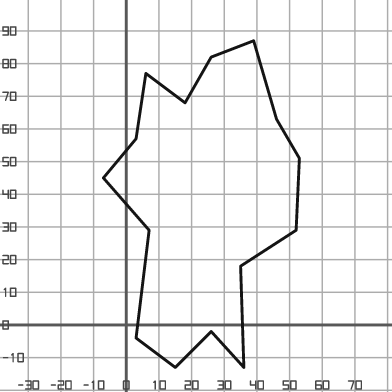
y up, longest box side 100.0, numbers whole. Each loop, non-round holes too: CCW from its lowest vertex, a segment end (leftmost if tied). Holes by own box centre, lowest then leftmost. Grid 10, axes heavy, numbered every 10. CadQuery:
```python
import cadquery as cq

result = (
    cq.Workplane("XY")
    .moveTo(15.0, -13.0)
    .lineTo(26.0, -2.0)
    .lineTo(36.0, -13.0)
    .lineTo(35.0, 18.0)
    .lineTo(52.0, 29.0)
    .lineTo(53.0, 51.0)
    .lineTo(46.0, 63.0)
    .lineTo(39.0, 87.0)
    .lineTo(26.0, 82.0)
    .lineTo(18.0, 68.0)
    .lineTo(6.0, 77.0)
    .lineTo(3.0, 57.0)
    .lineTo(-7.0, 45.0)
    .lineTo(7.0, 29.0)
    .lineTo(3.0, -4.0)
    .close()
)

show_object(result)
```